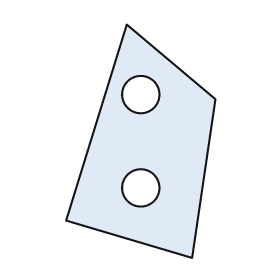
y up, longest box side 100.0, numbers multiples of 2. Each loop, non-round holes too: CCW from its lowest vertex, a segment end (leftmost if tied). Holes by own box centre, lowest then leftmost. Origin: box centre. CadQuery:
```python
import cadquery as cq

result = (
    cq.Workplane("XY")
    .moveTo(22.0, -50.0)
    .lineTo(32.0, 18.0)
    .lineTo(-6.0, 50.0)
    .lineTo(-32.0, -34.0)
    .close()
    .moveTo(0.0, -20.0)
    .circle(8.0)
    .moveTo(0.0, 20.0)
    .circle(8.0)
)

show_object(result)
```